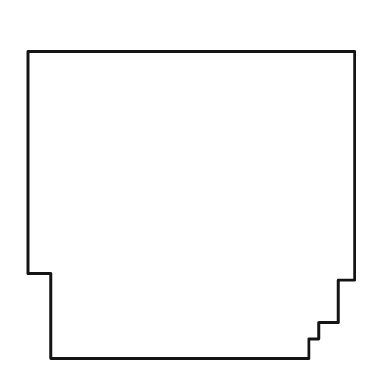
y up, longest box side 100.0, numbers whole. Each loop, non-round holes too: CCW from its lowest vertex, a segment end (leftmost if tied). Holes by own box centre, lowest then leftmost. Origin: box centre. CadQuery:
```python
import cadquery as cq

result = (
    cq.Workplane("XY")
    .moveTo(-43.0, -47.0)
    .lineTo(36.0, -47.0)
    .lineTo(36.0, -41.0)
    .lineTo(39.0, -41.0)
    .lineTo(39.0, -36.0)
    .lineTo(45.0, -36.0)
    .lineTo(45.0, -23.0)
    .lineTo(50.0, -23.0)
    .lineTo(50.0, 47.0)
    .lineTo(-50.0, 47.0)
    .lineTo(-50.0, -21.0)
    .lineTo(-43.0, -21.0)
    .close()
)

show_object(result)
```